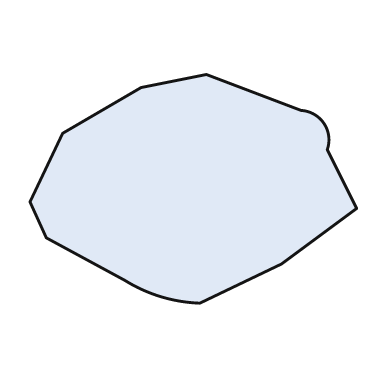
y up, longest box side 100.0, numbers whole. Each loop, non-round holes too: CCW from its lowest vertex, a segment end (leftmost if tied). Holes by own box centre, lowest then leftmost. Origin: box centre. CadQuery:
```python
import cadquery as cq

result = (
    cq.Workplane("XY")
    .moveTo(2.0, -35.0)
    .lineTo(27.0, -23.0)
    .lineTo(50.0, -6.0)
    .lineTo(41.0, 12.0)
    .threePointArc((40.0, 20.0), (33.0, 24.0))
    .lineTo(4.0, 35.0)
    .lineTo(-16.0, 31.0)
    .lineTo(-40.0, 17.0)
    .lineTo(-50.0, -4.0)
    .lineTo(-45.0, -15.0)
    .lineTo(-21.0, -28.0)
    .threePointArc((-10.0, -33.0), (2.0, -35.0))
    .close()
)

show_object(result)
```